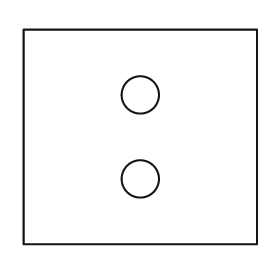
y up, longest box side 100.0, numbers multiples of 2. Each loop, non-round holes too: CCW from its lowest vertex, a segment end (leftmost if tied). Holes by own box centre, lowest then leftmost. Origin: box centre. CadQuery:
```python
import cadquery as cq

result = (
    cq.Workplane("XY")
    .moveTo(-50.0, -46.0)
    .lineTo(50.0, -46.0)
    .lineTo(50.0, 46.0)
    .lineTo(-50.0, 46.0)
    .close()
    .moveTo(0.0, -18.0)
    .circle(8.0)
    .moveTo(0.0, 18.0)
    .circle(8.0)
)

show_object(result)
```